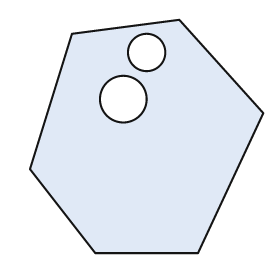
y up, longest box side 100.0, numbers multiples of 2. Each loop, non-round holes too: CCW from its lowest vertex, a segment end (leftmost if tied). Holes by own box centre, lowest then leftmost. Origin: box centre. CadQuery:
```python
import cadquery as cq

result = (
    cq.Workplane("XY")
    .moveTo(-22.0, -50.0)
    .lineTo(22.0, -50.0)
    .lineTo(50.0, 10.0)
    .lineTo(14.0, 50.0)
    .lineTo(-32.0, 44.0)
    .lineTo(-50.0, -14.0)
    .close()
    .moveTo(-10.0, 16.0)
    .circle(10.0)
    .moveTo(0.0, 36.0)
    .circle(8.0)
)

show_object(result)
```